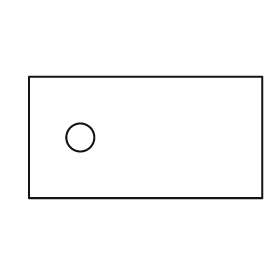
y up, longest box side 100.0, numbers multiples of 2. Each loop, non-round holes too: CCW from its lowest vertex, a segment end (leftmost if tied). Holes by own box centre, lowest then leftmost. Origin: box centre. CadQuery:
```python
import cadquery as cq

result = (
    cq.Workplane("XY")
    .moveTo(-50.0, -26.0)
    .lineTo(50.0, -26.0)
    .lineTo(50.0, 26.0)
    .lineTo(-50.0, 26.0)
    .close()
    .moveTo(-28.0, 0.0)
    .circle(6.0)
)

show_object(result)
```